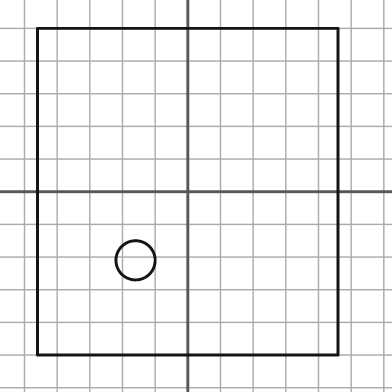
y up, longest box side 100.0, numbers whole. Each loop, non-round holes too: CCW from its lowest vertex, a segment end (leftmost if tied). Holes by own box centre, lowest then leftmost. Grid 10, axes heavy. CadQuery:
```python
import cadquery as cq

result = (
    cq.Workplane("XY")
    .moveTo(-46.0, -50.0)
    .lineTo(46.0, -50.0)
    .lineTo(46.0, 50.0)
    .lineTo(-46.0, 50.0)
    .close()
    .moveTo(-16.0, -21.0)
    .circle(6.0)
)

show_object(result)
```